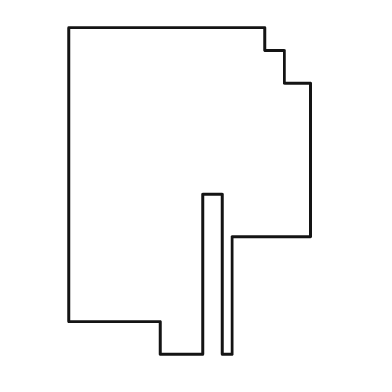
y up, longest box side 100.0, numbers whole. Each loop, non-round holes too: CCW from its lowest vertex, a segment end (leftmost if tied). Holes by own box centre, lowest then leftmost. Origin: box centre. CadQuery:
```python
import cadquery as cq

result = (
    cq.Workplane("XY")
    .moveTo(-9.0, -50.0)
    .lineTo(4.0, -50.0)
    .lineTo(4.0, -1.0)
    .lineTo(10.0, -1.0)
    .lineTo(10.0, -50.0)
    .lineTo(13.0, -50.0)
    .lineTo(13.0, -14.0)
    .lineTo(37.0, -14.0)
    .lineTo(37.0, 33.0)
    .lineTo(29.0, 33.0)
    .lineTo(29.0, 43.0)
    .lineTo(23.0, 43.0)
    .lineTo(23.0, 50.0)
    .lineTo(-37.0, 50.0)
    .lineTo(-37.0, -40.0)
    .lineTo(-9.0, -40.0)
    .close()
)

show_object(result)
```